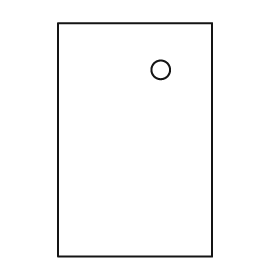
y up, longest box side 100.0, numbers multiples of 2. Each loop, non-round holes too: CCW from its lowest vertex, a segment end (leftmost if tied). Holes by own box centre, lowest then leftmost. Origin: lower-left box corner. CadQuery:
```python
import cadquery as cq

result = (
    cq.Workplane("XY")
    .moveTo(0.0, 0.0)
    .lineTo(66.0, 0.0)
    .lineTo(66.0, 100.0)
    .lineTo(0.0, 100.0)
    .close()
    .moveTo(44.0, 80.0)
    .circle(4.0)
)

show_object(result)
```